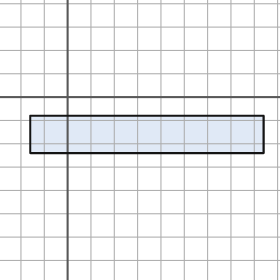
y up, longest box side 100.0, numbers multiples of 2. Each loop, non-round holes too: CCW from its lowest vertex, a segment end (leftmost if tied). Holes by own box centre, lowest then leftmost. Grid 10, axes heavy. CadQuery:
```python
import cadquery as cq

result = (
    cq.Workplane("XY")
    .moveTo(-16.0, -24.0)
    .lineTo(84.0, -24.0)
    .lineTo(84.0, -8.0)
    .lineTo(-16.0, -8.0)
    .close()
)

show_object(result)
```